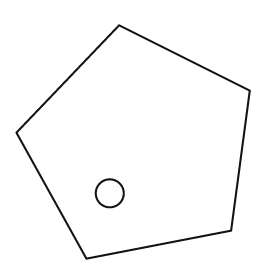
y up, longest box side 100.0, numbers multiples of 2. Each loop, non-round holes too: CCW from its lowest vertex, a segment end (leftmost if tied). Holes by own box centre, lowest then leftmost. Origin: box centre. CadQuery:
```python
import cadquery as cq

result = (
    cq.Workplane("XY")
    .moveTo(-20.0, -50.0)
    .lineTo(42.0, -38.0)
    .lineTo(50.0, 22.0)
    .lineTo(-6.0, 50.0)
    .lineTo(-50.0, 4.0)
    .close()
    .moveTo(-10.0, -22.0)
    .circle(6.0)
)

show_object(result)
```